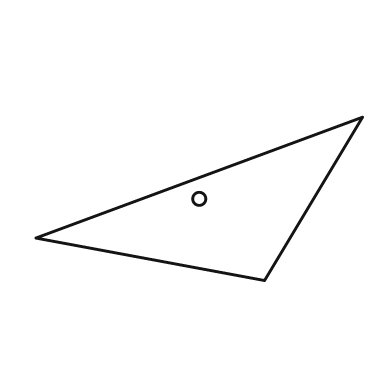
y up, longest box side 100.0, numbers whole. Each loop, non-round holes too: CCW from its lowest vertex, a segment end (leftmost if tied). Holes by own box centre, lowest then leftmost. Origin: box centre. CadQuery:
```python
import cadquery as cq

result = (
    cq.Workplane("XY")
    .moveTo(20.0, -25.0)
    .lineTo(50.0, 25.0)
    .lineTo(-50.0, -12.0)
    .close()
    .moveTo(0.0, 0.0)
    .circle(2.0)
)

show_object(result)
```